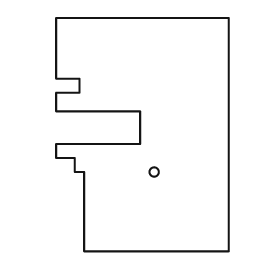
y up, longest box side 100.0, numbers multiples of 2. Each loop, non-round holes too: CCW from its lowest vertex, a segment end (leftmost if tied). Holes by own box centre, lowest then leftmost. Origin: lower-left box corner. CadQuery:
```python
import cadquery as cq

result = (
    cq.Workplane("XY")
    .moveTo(12.0, 0.0)
    .lineTo(74.0, 0.0)
    .lineTo(74.0, 100.0)
    .lineTo(0.0, 100.0)
    .lineTo(0.0, 74.0)
    .lineTo(10.0, 74.0)
    .lineTo(10.0, 68.0)
    .lineTo(0.0, 68.0)
    .lineTo(0.0, 60.0)
    .lineTo(36.0, 60.0)
    .lineTo(36.0, 46.0)
    .lineTo(0.0, 46.0)
    .lineTo(0.0, 40.0)
    .lineTo(8.0, 40.0)
    .lineTo(8.0, 34.0)
    .lineTo(12.0, 34.0)
    .close()
    .moveTo(42.0, 34.0)
    .circle(2.0)
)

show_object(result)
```